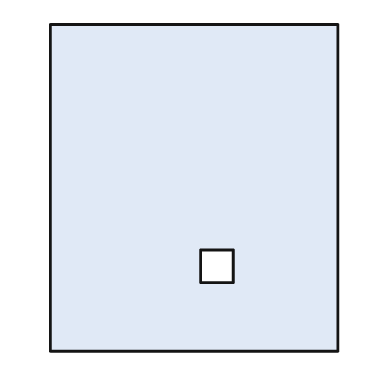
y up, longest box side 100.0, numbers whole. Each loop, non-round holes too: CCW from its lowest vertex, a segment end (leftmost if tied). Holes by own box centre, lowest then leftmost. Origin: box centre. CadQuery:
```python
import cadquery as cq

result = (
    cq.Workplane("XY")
    .moveTo(-44.0, -50.0)
    .lineTo(44.0, -50.0)
    .lineTo(44.0, 50.0)
    .lineTo(-44.0, 50.0)
    .close()
    .moveTo(2.0, -29.0)
    .lineTo(12.0, -29.0)
    .lineTo(12.0, -19.0)
    .lineTo(2.0, -19.0)
    .close()
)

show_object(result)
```